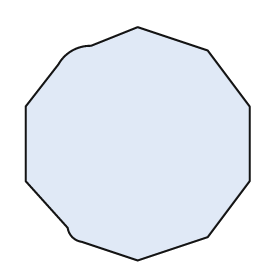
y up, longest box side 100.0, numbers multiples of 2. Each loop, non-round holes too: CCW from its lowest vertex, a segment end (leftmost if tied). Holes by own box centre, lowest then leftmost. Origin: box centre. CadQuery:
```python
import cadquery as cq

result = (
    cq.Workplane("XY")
    .moveTo(0.0, -50.0)
    .lineTo(30.0, -40.0)
    .lineTo(48.0, -16.0)
    .lineTo(48.0, 16.0)
    .lineTo(30.0, 40.0)
    .lineTo(0.0, 50.0)
    .lineTo(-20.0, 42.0)
    .threePointArc((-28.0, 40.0), (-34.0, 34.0))
    .lineTo(-48.0, 16.0)
    .lineTo(-48.0, -16.0)
    .lineTo(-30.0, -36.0)
    .threePointArc((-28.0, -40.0), (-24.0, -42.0))
    .close()
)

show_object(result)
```